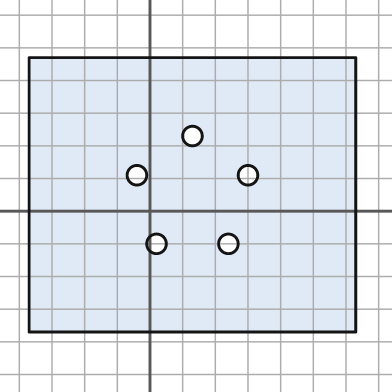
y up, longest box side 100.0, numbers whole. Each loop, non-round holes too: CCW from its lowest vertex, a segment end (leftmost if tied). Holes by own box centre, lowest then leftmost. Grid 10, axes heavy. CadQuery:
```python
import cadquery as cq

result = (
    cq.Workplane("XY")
    .moveTo(-37.0, -37.0)
    .lineTo(63.0, -37.0)
    .lineTo(63.0, 47.0)
    .lineTo(-37.0, 47.0)
    .close()
    .moveTo(2.0, -10.0)
    .circle(3.0)
    .moveTo(24.0, -10.0)
    .circle(3.0)
    .moveTo(-4.0, 11.0)
    .circle(3.0)
    .moveTo(30.0, 11.0)
    .circle(3.0)
    .moveTo(13.0, 23.0)
    .circle(3.0)
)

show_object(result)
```